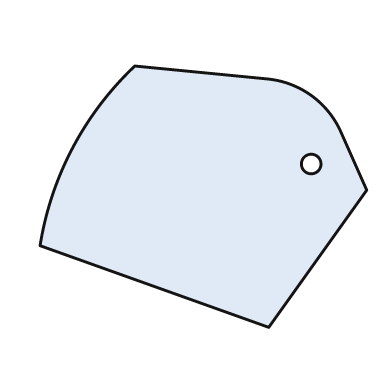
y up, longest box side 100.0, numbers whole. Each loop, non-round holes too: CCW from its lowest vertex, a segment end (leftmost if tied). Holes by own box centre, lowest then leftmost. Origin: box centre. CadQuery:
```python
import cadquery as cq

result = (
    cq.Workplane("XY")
    .moveTo(20.0, -40.0)
    .lineTo(50.0, 2.0)
    .lineTo(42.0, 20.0)
    .threePointArc((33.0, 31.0), (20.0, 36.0))
    .lineTo(-21.0, 40.0)
    .threePointArc((-40.0, 15.0), (-50.0, -15.0))
    .close()
    .moveTo(33.0, 10.0)
    .circle(3.0)
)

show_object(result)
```